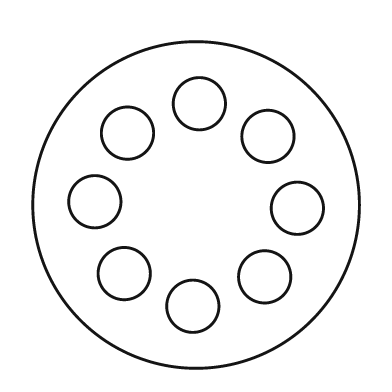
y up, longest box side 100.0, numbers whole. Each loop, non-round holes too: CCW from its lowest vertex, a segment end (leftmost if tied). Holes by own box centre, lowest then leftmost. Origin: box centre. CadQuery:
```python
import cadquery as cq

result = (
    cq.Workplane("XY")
    .moveTo(0.0, 0.0)
    .circle(50.0)
    .moveTo(-1.0, -31.0)
    .circle(8.0)
    .moveTo(21.0, -22.0)
    .circle(8.0)
    .moveTo(-22.0, -21.0)
    .circle(8.0)
    .moveTo(31.0, -1.0)
    .circle(8.0)
    .moveTo(-31.0, 1.0)
    .circle(8.0)
    .moveTo(22.0, 21.0)
    .circle(8.0)
    .moveTo(-21.0, 22.0)
    .circle(8.0)
    .moveTo(1.0, 31.0)
    .circle(8.0)
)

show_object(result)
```